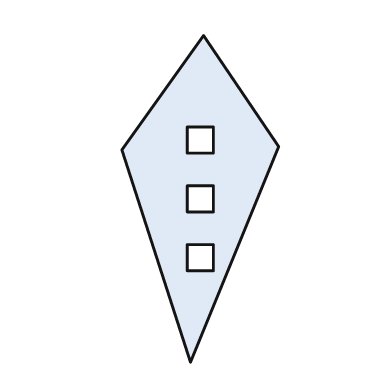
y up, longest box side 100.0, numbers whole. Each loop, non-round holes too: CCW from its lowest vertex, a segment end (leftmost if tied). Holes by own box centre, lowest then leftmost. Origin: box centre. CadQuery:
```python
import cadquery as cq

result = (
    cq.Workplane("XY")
    .moveTo(-3.0, -50.0)
    .lineTo(24.0, 16.0)
    .lineTo(1.0, 50.0)
    .lineTo(-24.0, 15.0)
    .close()
    .moveTo(-4.0, -22.0)
    .lineTo(4.0, -22.0)
    .lineTo(4.0, -14.0)
    .lineTo(-4.0, -14.0)
    .close()
    .moveTo(-4.0, -4.0)
    .lineTo(4.0, -4.0)
    .lineTo(4.0, 4.0)
    .lineTo(-4.0, 4.0)
    .close()
    .moveTo(-4.0, 14.0)
    .lineTo(4.0, 14.0)
    .lineTo(4.0, 22.0)
    .lineTo(-4.0, 22.0)
    .close()
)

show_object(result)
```